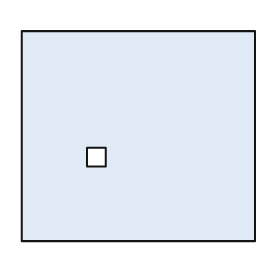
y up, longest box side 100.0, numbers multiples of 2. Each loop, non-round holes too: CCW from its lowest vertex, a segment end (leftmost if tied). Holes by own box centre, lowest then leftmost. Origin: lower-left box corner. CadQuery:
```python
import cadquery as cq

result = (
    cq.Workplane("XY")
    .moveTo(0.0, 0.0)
    .lineTo(100.0, 0.0)
    .lineTo(100.0, 90.0)
    .lineTo(0.0, 90.0)
    .close()
    .moveTo(28.0, 32.0)
    .lineTo(36.0, 32.0)
    .lineTo(36.0, 40.0)
    .lineTo(28.0, 40.0)
    .close()
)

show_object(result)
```